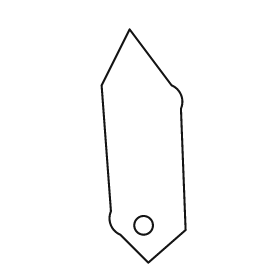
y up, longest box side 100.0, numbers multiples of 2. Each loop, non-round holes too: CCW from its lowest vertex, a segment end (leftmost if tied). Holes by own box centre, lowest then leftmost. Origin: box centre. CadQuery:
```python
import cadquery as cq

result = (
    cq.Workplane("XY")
    .moveTo(2.0, -50.0)
    .lineTo(18.0, -36.0)
    .lineTo(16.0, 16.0)
    .threePointArc((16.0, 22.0), (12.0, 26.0))
    .lineTo(-6.0, 50.0)
    .lineTo(-18.0, 26.0)
    .lineTo(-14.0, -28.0)
    .threePointArc((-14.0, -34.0), (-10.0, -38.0))
    .close()
    .moveTo(0.0, -34.0)
    .circle(4.0)
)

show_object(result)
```